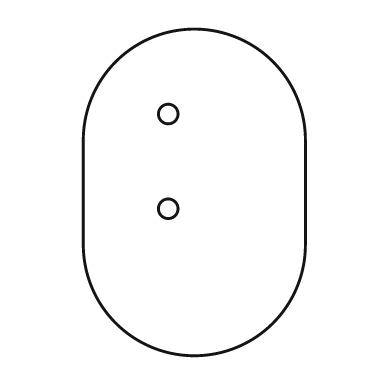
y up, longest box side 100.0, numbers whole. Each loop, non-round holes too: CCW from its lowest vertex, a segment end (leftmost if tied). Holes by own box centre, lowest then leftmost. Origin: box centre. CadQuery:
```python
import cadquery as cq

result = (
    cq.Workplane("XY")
    .moveTo(-34.0, -16.0)
    .threePointArc((0.0, -50.0), (34.0, -16.0))
    .lineTo(34.0, 16.0)
    .threePointArc((0.0, 50.0), (-34.0, 16.0))
    .close()
    .moveTo(-8.0, -5.0)
    .circle(3.0)
    .moveTo(-8.0, 24.0)
    .circle(3.0)
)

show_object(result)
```